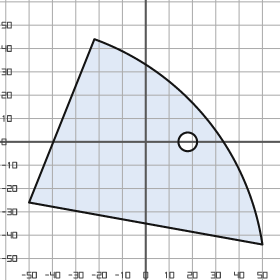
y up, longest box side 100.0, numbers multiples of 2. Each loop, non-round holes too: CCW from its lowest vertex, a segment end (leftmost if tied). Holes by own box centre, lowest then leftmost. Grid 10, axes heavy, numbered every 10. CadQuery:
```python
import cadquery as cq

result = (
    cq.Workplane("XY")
    .moveTo(50.0, -44.0)
    .threePointArc((26.0, 10.0), (-22.0, 44.0))
    .lineTo(-50.0, -26.0)
    .close()
    .moveTo(18.0, 0.0)
    .circle(4.0)
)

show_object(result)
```